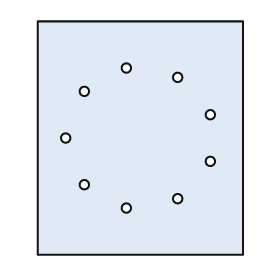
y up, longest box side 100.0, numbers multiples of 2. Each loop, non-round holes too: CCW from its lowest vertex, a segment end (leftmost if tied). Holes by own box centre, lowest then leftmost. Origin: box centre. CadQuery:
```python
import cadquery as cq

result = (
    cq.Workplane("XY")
    .moveTo(-44.0, -50.0)
    .lineTo(44.0, -50.0)
    .lineTo(44.0, 50.0)
    .lineTo(-44.0, 50.0)
    .close()
    .moveTo(-6.0, -30.0)
    .circle(2.0)
    .moveTo(16.0, -26.0)
    .circle(2.0)
    .moveTo(-24.0, -20.0)
    .circle(2.0)
    .moveTo(30.0, -10.0)
    .circle(2.0)
    .moveTo(-32.0, 0.0)
    .circle(2.0)
    .moveTo(30.0, 10.0)
    .circle(2.0)
    .moveTo(-24.0, 20.0)
    .circle(2.0)
    .moveTo(16.0, 26.0)
    .circle(2.0)
    .moveTo(-6.0, 30.0)
    .circle(2.0)
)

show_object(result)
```